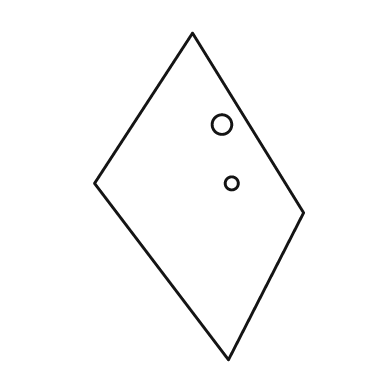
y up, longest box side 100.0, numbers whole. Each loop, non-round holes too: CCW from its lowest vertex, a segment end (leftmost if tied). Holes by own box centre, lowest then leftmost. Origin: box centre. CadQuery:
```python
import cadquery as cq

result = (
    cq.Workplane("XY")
    .moveTo(9.0, -50.0)
    .lineTo(32.0, -5.0)
    .lineTo(-2.0, 50.0)
    .lineTo(-32.0, 4.0)
    .close()
    .moveTo(10.0, 4.0)
    .circle(2.0)
    .moveTo(7.0, 22.0)
    .circle(3.0)
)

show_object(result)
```